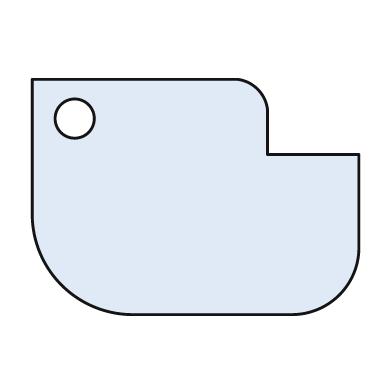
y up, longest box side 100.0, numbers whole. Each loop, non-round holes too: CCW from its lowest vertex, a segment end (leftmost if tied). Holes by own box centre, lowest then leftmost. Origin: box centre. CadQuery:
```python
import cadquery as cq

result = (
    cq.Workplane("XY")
    .moveTo(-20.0, -36.0)
    .lineTo(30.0, -36.0)
    .threePointArc((44.0, -30.0), (50.0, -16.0))
    .lineTo(50.0, 13.0)
    .lineTo(22.0, 13.0)
    .lineTo(22.0, 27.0)
    .threePointArc((19.0, 33.0), (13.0, 36.0))
    .lineTo(-50.0, 36.0)
    .lineTo(-50.0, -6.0)
    .threePointArc((-41.0, -27.0), (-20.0, -36.0))
    .close()
    .moveTo(-37.0, 24.0)
    .circle(6.0)
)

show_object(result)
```